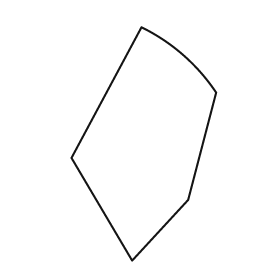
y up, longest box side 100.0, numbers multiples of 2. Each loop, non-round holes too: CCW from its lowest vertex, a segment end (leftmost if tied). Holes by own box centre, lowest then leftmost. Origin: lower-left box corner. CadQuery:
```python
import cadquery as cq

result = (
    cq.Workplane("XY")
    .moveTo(26.0, 0.0)
    .lineTo(50.0, 26.0)
    .lineTo(62.0, 72.0)
    .threePointArc((48.0, 88.0), (30.0, 100.0))
    .lineTo(0.0, 44.0)
    .close()
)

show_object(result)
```